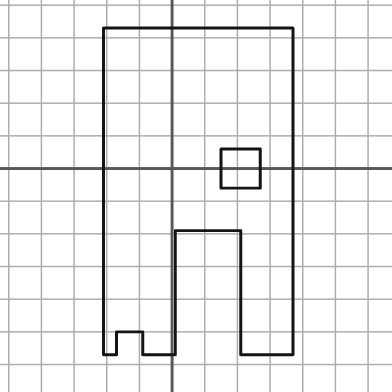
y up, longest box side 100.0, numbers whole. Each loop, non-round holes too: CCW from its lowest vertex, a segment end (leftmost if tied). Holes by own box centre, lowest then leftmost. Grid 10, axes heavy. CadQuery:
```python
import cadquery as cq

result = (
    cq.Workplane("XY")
    .moveTo(-21.0, -57.0)
    .lineTo(-17.0, -57.0)
    .lineTo(-17.0, -50.0)
    .lineTo(-9.0, -50.0)
    .lineTo(-9.0, -57.0)
    .lineTo(1.0, -57.0)
    .lineTo(1.0, -19.0)
    .lineTo(21.0, -19.0)
    .lineTo(21.0, -57.0)
    .lineTo(37.0, -57.0)
    .lineTo(37.0, 43.0)
    .lineTo(-21.0, 43.0)
    .close()
    .moveTo(15.0, -6.0)
    .lineTo(27.0, -6.0)
    .lineTo(27.0, 6.0)
    .lineTo(15.0, 6.0)
    .close()
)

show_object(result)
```